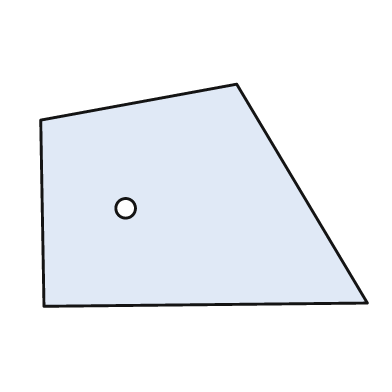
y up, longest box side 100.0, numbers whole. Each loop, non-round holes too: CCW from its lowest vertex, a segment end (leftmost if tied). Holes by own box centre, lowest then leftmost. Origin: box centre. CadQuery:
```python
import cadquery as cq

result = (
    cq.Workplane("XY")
    .moveTo(-49.0, -34.0)
    .lineTo(50.0, -33.0)
    .lineTo(10.0, 34.0)
    .lineTo(-50.0, 23.0)
    .close()
    .moveTo(-24.0, -4.0)
    .circle(3.0)
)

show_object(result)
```